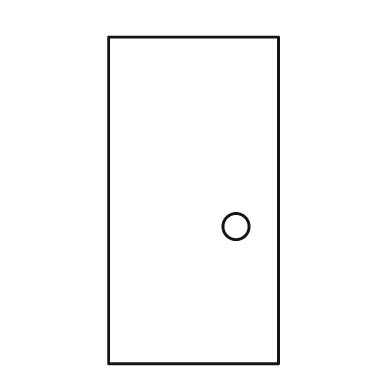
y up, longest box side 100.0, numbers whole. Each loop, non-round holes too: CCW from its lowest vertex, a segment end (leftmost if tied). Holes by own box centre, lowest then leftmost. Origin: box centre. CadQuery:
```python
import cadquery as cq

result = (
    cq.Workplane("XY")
    .moveTo(-26.0, -50.0)
    .lineTo(26.0, -50.0)
    .lineTo(26.0, 50.0)
    .lineTo(-26.0, 50.0)
    .close()
    .moveTo(13.0, -8.0)
    .circle(4.0)
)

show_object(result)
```